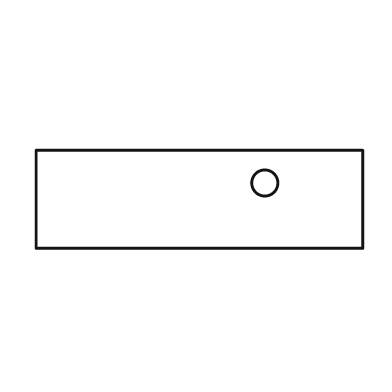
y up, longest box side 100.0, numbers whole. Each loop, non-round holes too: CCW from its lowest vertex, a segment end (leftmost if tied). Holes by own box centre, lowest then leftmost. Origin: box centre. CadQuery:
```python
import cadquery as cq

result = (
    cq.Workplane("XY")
    .moveTo(-50.0, -15.0)
    .lineTo(50.0, -15.0)
    .lineTo(50.0, 15.0)
    .lineTo(-50.0, 15.0)
    .close()
    .moveTo(20.0, 5.0)
    .circle(4.0)
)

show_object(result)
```